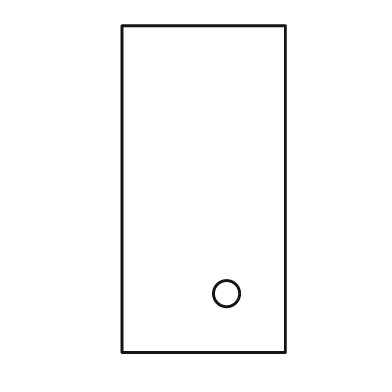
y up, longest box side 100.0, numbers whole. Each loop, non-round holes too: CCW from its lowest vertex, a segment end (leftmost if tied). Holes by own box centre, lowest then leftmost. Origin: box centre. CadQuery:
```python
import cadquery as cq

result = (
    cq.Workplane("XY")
    .moveTo(-25.0, -50.0)
    .lineTo(25.0, -50.0)
    .lineTo(25.0, 50.0)
    .lineTo(-25.0, 50.0)
    .close()
    .moveTo(7.0, -32.0)
    .circle(4.0)
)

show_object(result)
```